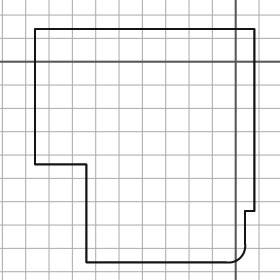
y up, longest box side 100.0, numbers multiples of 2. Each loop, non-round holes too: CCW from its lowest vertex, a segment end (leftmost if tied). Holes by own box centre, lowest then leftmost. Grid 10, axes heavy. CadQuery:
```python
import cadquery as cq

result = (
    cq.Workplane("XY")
    .moveTo(-64.0, -86.0)
    .lineTo(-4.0, -86.0)
    .threePointArc((2.0, -84.0), (4.0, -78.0))
    .lineTo(4.0, -64.0)
    .lineTo(8.0, -64.0)
    .lineTo(8.0, 14.0)
    .lineTo(-86.0, 14.0)
    .lineTo(-86.0, -44.0)
    .lineTo(-64.0, -44.0)
    .close()
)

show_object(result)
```